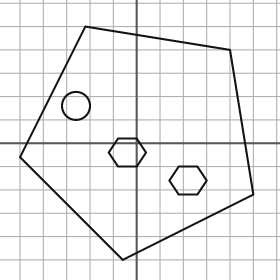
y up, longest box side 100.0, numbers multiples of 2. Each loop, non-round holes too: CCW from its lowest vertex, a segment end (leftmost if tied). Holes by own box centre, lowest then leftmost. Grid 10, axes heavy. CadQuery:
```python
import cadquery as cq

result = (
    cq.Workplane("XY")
    .moveTo(-6.0, -50.0)
    .lineTo(50.0, -22.0)
    .lineTo(40.0, 40.0)
    .lineTo(-22.0, 50.0)
    .lineTo(-50.0, -6.0)
    .close()
    .moveTo(18.0, -22.0)
    .lineTo(26.0, -22.0)
    .lineTo(30.0, -16.0)
    .lineTo(26.0, -10.0)
    .lineTo(18.0, -10.0)
    .lineTo(14.0, -16.0)
    .close()
    .moveTo(-8.0, -10.0)
    .lineTo(0.0, -10.0)
    .lineTo(4.0, -4.0)
    .lineTo(0.0, 2.0)
    .lineTo(-8.0, 2.0)
    .lineTo(-12.0, -4.0)
    .close()
    .moveTo(-26.0, 16.0)
    .circle(6.0)
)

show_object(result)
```